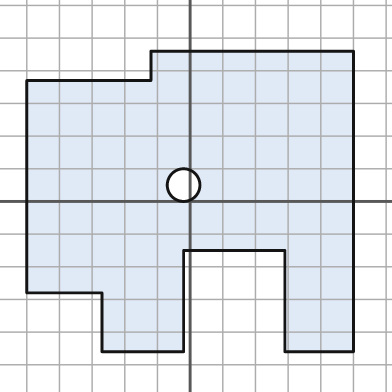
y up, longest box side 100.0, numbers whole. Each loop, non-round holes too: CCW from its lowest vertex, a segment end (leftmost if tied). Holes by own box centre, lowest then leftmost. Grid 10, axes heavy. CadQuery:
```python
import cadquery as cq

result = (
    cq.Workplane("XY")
    .moveTo(-27.0, -46.0)
    .lineTo(-2.0, -46.0)
    .lineTo(-2.0, -15.0)
    .lineTo(29.0, -15.0)
    .lineTo(29.0, -46.0)
    .lineTo(50.0, -46.0)
    .lineTo(50.0, 46.0)
    .lineTo(-12.0, 46.0)
    .lineTo(-12.0, 37.0)
    .lineTo(-50.0, 37.0)
    .lineTo(-50.0, -28.0)
    .lineTo(-27.0, -28.0)
    .close()
    .moveTo(-2.0, 5.0)
    .circle(5.0)
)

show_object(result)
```